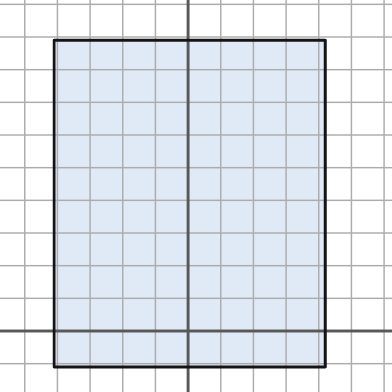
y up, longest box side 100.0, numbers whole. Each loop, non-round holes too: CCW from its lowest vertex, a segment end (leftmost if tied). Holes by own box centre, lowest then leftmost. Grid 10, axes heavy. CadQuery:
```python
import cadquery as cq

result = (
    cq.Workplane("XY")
    .moveTo(-41.0, -11.0)
    .lineTo(42.0, -11.0)
    .lineTo(42.0, 89.0)
    .lineTo(-41.0, 89.0)
    .close()
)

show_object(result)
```